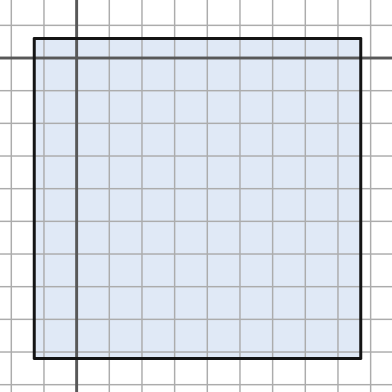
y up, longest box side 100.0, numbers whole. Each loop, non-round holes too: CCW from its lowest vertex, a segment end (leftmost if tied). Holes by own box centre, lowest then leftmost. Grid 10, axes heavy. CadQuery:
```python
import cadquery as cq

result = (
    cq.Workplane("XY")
    .moveTo(-13.0, -92.0)
    .lineTo(87.0, -92.0)
    .lineTo(87.0, 6.0)
    .lineTo(-13.0, 6.0)
    .close()
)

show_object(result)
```